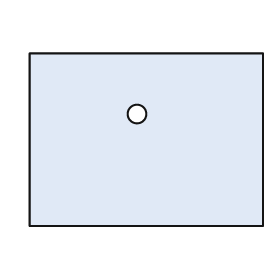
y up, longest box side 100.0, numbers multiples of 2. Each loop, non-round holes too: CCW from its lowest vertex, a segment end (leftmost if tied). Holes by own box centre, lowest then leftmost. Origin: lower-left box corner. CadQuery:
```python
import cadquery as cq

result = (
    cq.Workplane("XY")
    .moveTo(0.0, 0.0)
    .lineTo(100.0, 0.0)
    .lineTo(100.0, 74.0)
    .lineTo(0.0, 74.0)
    .close()
    .moveTo(46.0, 48.0)
    .circle(4.0)
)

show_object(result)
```